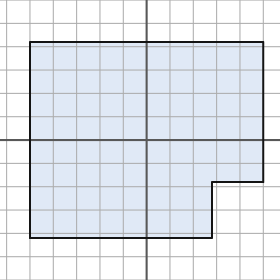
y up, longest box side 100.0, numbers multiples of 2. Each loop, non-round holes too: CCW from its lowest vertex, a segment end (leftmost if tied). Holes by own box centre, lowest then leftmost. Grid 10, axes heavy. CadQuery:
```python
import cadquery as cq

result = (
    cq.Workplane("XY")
    .moveTo(-50.0, -42.0)
    .lineTo(28.0, -42.0)
    .lineTo(28.0, -18.0)
    .lineTo(50.0, -18.0)
    .lineTo(50.0, 42.0)
    .lineTo(-50.0, 42.0)
    .close()
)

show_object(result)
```